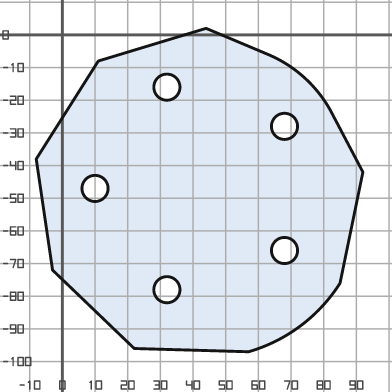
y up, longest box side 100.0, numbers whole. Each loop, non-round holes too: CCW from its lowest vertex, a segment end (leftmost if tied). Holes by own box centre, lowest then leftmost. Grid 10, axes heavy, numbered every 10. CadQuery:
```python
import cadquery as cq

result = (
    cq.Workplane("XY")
    .moveTo(57.0, -97.0)
    .threePointArc((73.0, -89.0), (85.0, -76.0))
    .lineTo(92.0, -42.0)
    .lineTo(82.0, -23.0)
    .threePointArc((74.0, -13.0), (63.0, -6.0))
    .lineTo(44.0, 2.0)
    .lineTo(11.0, -8.0)
    .lineTo(-8.0, -38.0)
    .lineTo(-3.0, -72.0)
    .lineTo(22.0, -96.0)
    .close()
    .moveTo(32.0, -78.0)
    .circle(4.0)
    .moveTo(68.0, -66.0)
    .circle(4.0)
    .moveTo(10.0, -47.0)
    .circle(4.0)
    .moveTo(68.0, -28.0)
    .circle(4.0)
    .moveTo(32.0, -16.0)
    .circle(4.0)
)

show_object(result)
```